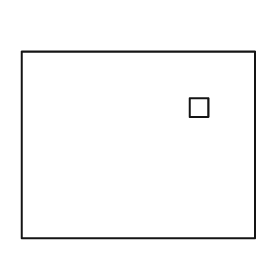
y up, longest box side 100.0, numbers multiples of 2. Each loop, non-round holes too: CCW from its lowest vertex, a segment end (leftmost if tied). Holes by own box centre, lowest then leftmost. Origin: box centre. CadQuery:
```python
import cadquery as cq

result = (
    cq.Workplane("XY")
    .moveTo(-50.0, -40.0)
    .lineTo(50.0, -40.0)
    .lineTo(50.0, 40.0)
    .lineTo(-50.0, 40.0)
    .close()
    .moveTo(22.0, 12.0)
    .lineTo(30.0, 12.0)
    .lineTo(30.0, 20.0)
    .lineTo(22.0, 20.0)
    .close()
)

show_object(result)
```